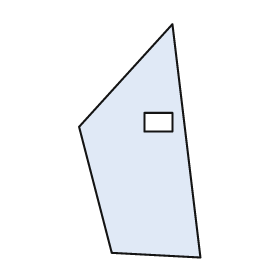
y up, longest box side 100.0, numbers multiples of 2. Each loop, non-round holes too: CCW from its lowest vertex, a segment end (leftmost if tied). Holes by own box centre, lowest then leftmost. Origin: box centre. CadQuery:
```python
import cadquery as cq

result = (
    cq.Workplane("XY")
    .moveTo(26.0, -50.0)
    .lineTo(14.0, 50.0)
    .lineTo(-26.0, 6.0)
    .lineTo(-12.0, -48.0)
    .close()
    .moveTo(2.0, 4.0)
    .lineTo(14.0, 4.0)
    .lineTo(14.0, 12.0)
    .lineTo(2.0, 12.0)
    .close()
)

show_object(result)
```